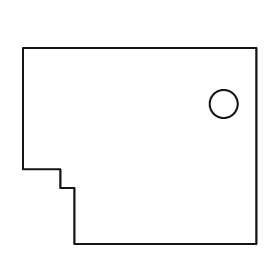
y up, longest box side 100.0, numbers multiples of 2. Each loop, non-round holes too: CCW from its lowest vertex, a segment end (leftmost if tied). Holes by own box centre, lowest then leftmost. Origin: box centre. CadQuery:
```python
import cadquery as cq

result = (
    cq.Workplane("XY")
    .moveTo(-28.0, -42.0)
    .lineTo(50.0, -42.0)
    .lineTo(50.0, 42.0)
    .lineTo(-50.0, 42.0)
    .lineTo(-50.0, -10.0)
    .lineTo(-34.0, -10.0)
    .lineTo(-34.0, -18.0)
    .lineTo(-28.0, -18.0)
    .close()
    .moveTo(36.0, 18.0)
    .circle(6.0)
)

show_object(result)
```